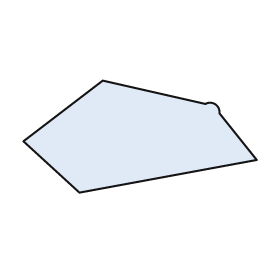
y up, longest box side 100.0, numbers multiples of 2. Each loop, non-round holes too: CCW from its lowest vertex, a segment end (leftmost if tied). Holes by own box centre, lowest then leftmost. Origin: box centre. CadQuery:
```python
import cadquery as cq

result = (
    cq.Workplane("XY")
    .moveTo(-26.0, -24.0)
    .lineTo(50.0, -10.0)
    .lineTo(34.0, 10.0)
    .threePointArc((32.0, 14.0), (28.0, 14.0))
    .lineTo(-16.0, 24.0)
    .lineTo(-50.0, -2.0)
    .close()
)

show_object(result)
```